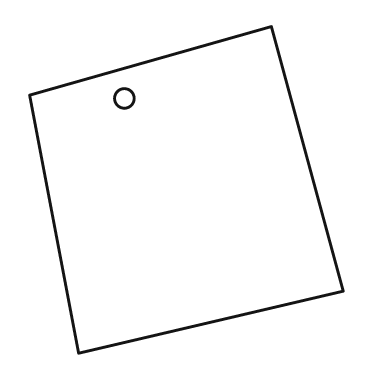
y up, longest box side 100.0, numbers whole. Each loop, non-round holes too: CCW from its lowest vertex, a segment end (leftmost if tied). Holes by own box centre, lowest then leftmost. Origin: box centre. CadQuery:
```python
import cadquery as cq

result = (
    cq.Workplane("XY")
    .moveTo(-33.0, -50.0)
    .lineTo(48.0, -31.0)
    .lineTo(26.0, 50.0)
    .lineTo(-48.0, 29.0)
    .close()
    .moveTo(-19.0, 28.0)
    .circle(3.0)
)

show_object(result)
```